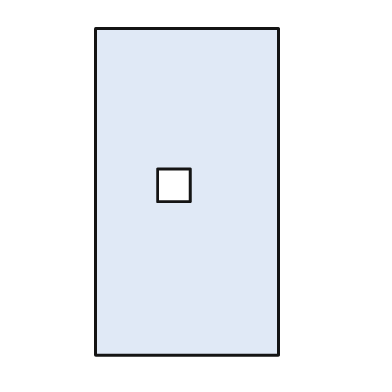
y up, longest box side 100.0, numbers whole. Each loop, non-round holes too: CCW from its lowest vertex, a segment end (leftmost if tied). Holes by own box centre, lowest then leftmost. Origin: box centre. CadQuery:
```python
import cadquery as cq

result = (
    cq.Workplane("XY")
    .moveTo(-28.0, -50.0)
    .lineTo(28.0, -50.0)
    .lineTo(28.0, 50.0)
    .lineTo(-28.0, 50.0)
    .close()
    .moveTo(-9.0, -3.0)
    .lineTo(1.0, -3.0)
    .lineTo(1.0, 7.0)
    .lineTo(-9.0, 7.0)
    .close()
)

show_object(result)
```